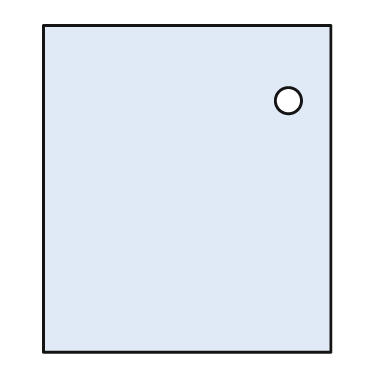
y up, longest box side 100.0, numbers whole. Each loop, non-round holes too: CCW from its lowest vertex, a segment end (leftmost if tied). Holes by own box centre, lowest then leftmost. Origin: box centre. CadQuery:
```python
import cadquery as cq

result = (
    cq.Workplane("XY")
    .moveTo(-44.0, -50.0)
    .lineTo(44.0, -50.0)
    .lineTo(44.0, 50.0)
    .lineTo(-44.0, 50.0)
    .close()
    .moveTo(31.0, 27.0)
    .circle(4.0)
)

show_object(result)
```